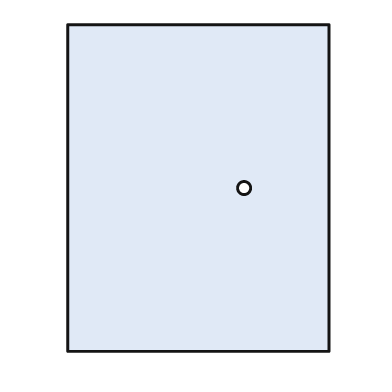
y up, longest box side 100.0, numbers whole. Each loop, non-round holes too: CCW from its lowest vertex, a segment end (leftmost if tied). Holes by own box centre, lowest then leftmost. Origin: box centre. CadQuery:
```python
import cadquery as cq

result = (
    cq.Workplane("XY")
    .moveTo(-40.0, -50.0)
    .lineTo(40.0, -50.0)
    .lineTo(40.0, 50.0)
    .lineTo(-40.0, 50.0)
    .close()
    .moveTo(14.0, 0.0)
    .circle(2.0)
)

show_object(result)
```